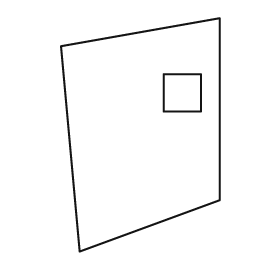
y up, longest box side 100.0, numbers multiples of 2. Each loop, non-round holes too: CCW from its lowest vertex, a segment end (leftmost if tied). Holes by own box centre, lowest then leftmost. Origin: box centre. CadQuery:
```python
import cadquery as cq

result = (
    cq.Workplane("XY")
    .moveTo(-26.0, -50.0)
    .lineTo(34.0, -28.0)
    .lineTo(34.0, 50.0)
    .lineTo(-34.0, 38.0)
    .close()
    .moveTo(10.0, 10.0)
    .lineTo(26.0, 10.0)
    .lineTo(26.0, 26.0)
    .lineTo(10.0, 26.0)
    .close()
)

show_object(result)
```